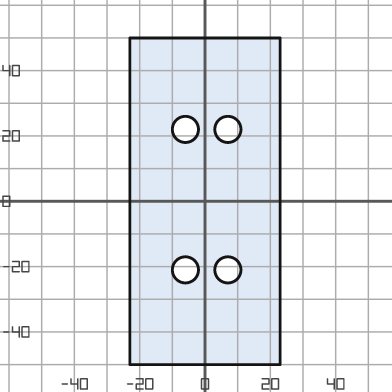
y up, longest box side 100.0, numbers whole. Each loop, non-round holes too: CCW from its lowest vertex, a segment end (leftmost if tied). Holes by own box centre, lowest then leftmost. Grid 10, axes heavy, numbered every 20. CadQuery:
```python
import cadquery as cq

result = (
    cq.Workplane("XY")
    .moveTo(-23.0, -50.0)
    .lineTo(23.0, -50.0)
    .lineTo(23.0, 50.0)
    .lineTo(-23.0, 50.0)
    .close()
    .moveTo(-6.0, -21.0)
    .circle(4.0)
    .moveTo(7.0, -21.0)
    .circle(4.0)
    .moveTo(-6.0, 22.0)
    .circle(4.0)
    .moveTo(7.0, 22.0)
    .circle(4.0)
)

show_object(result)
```